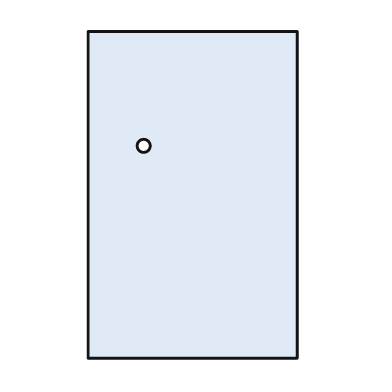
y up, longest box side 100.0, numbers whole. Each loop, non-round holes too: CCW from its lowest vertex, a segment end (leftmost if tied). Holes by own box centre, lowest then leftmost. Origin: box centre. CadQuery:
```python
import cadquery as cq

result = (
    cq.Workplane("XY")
    .moveTo(-32.0, -50.0)
    .lineTo(32.0, -50.0)
    .lineTo(32.0, 50.0)
    .lineTo(-32.0, 50.0)
    .close()
    .moveTo(-15.0, 15.0)
    .circle(2.0)
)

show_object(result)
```